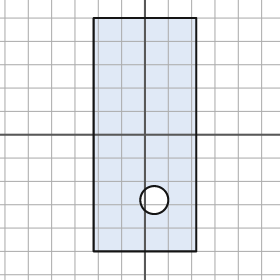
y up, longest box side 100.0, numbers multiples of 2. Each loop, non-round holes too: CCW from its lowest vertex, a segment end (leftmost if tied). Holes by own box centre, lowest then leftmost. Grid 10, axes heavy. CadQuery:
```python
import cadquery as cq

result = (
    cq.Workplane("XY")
    .moveTo(-22.0, -50.0)
    .lineTo(22.0, -50.0)
    .lineTo(22.0, 50.0)
    .lineTo(-22.0, 50.0)
    .close()
    .moveTo(4.0, -28.0)
    .circle(6.0)
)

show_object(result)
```